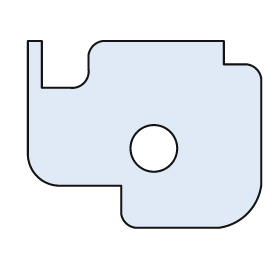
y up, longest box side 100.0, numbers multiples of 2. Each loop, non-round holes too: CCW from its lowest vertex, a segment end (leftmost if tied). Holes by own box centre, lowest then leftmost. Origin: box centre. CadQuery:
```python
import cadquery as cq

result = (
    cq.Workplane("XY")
    .moveTo(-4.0, -40.0)
    .lineTo(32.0, -40.0)
    .threePointArc((44.0, -34.0), (50.0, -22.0))
    .lineTo(50.0, 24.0)
    .threePointArc((48.0, 28.0), (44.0, 30.0))
    .lineTo(34.0, 30.0)
    .lineTo(34.0, 40.0)
    .lineTo(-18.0, 40.0)
    .threePointArc((-22.0, 38.0), (-24.0, 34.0))
    .lineTo(-24.0, 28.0)
    .threePointArc((-26.0, 22.0), (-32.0, 20.0))
    .lineTo(-44.0, 20.0)
    .lineTo(-44.0, 40.0)
    .lineTo(-50.0, 40.0)
    .lineTo(-50.0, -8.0)
    .threePointArc((-46.0, -18.0), (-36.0, -22.0))
    .lineTo(-10.0, -22.0)
    .lineTo(-10.0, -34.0)
    .threePointArc((-8.0, -38.0), (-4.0, -40.0))
    .close()
    .moveTo(4.0, -6.0)
    .circle(10.0)
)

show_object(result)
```